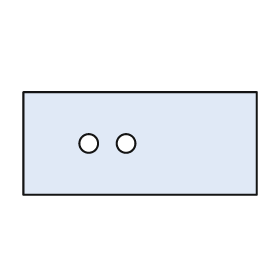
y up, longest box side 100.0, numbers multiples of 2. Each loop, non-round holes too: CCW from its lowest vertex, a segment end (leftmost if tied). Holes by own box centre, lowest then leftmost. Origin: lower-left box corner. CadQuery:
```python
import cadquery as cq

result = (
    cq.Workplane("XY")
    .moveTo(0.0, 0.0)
    .lineTo(100.0, 0.0)
    .lineTo(100.0, 44.0)
    .lineTo(0.0, 44.0)
    .close()
    .moveTo(28.0, 22.0)
    .circle(4.0)
    .moveTo(44.0, 22.0)
    .circle(4.0)
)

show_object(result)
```